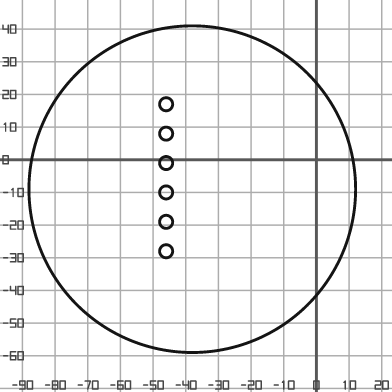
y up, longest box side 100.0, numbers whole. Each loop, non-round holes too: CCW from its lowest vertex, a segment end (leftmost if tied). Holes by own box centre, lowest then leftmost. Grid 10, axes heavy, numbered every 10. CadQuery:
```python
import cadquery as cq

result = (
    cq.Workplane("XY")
    .moveTo(-38.0, -9.0)
    .circle(50.0)
    .moveTo(-46.0, -28.0)
    .circle(2.0)
    .moveTo(-46.0, -19.0)
    .circle(2.0)
    .moveTo(-46.0, -10.0)
    .circle(2.0)
    .moveTo(-46.0, -1.0)
    .circle(2.0)
    .moveTo(-46.0, 8.0)
    .circle(2.0)
    .moveTo(-46.0, 17.0)
    .circle(2.0)
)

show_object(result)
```